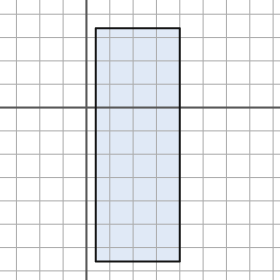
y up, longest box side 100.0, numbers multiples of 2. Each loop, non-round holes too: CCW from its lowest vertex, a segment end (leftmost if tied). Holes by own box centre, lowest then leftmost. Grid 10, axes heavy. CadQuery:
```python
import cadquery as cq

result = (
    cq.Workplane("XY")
    .moveTo(4.0, -66.0)
    .lineTo(40.0, -66.0)
    .lineTo(40.0, 34.0)
    .lineTo(4.0, 34.0)
    .close()
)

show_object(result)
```